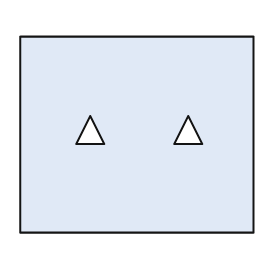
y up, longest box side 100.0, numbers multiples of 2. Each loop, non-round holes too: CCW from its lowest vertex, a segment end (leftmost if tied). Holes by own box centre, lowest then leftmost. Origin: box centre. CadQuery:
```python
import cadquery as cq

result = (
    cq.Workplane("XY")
    .moveTo(-50.0, -42.0)
    .lineTo(50.0, -42.0)
    .lineTo(50.0, 42.0)
    .lineTo(-50.0, 42.0)
    .close()
    .moveTo(-26.0, -4.0)
    .lineTo(-14.0, -4.0)
    .lineTo(-20.0, 8.0)
    .close()
    .moveTo(16.0, -4.0)
    .lineTo(28.0, -4.0)
    .lineTo(22.0, 8.0)
    .close()
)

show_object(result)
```